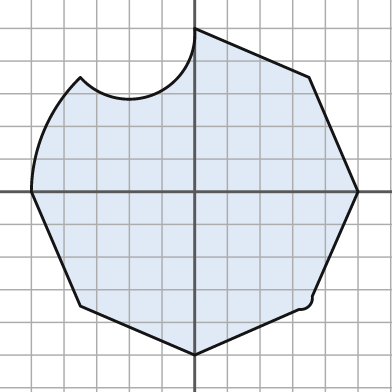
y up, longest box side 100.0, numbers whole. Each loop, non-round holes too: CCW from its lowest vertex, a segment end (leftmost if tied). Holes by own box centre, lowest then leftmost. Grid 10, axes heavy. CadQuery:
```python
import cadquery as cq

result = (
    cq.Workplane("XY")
    .moveTo(0.0, -50.0)
    .lineTo(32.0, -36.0)
    .threePointArc((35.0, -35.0), (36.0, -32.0))
    .lineTo(50.0, 0.0)
    .lineTo(35.0, 35.0)
    .lineTo(0.0, 50.0)
    .threePointArc((-12.0, 30.0), (-35.0, 35.0))
    .threePointArc((-46.0, 19.0), (-50.0, 0.0))
    .lineTo(-35.0, -35.0)
    .close()
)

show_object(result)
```